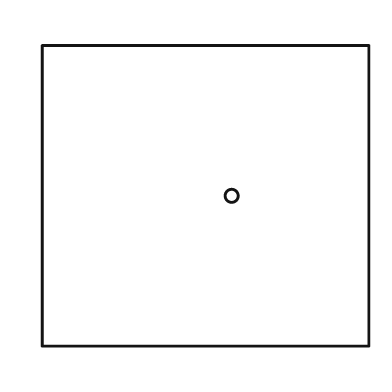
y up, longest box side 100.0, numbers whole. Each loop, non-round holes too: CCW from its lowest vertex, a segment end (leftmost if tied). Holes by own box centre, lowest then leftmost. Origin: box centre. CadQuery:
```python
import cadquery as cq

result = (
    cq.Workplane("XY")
    .moveTo(-50.0, -46.0)
    .lineTo(50.0, -46.0)
    .lineTo(50.0, 46.0)
    .lineTo(-50.0, 46.0)
    .close()
    .moveTo(8.0, 0.0)
    .circle(2.0)
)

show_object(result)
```